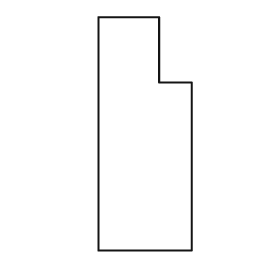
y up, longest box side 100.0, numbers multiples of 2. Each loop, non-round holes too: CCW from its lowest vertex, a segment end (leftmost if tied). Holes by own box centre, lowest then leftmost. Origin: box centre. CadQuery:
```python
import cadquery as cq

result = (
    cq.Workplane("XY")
    .moveTo(-20.0, -50.0)
    .lineTo(20.0, -50.0)
    .lineTo(20.0, 22.0)
    .lineTo(6.0, 22.0)
    .lineTo(6.0, 50.0)
    .lineTo(-20.0, 50.0)
    .close()
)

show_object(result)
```